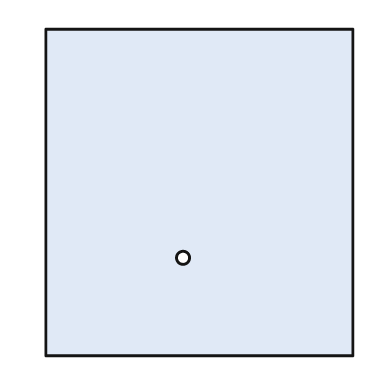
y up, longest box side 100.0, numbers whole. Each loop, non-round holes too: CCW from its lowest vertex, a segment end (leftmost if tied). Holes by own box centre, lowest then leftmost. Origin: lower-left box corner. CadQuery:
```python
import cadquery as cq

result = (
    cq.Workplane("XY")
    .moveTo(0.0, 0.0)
    .lineTo(94.0, 0.0)
    .lineTo(94.0, 100.0)
    .lineTo(0.0, 100.0)
    .close()
    .moveTo(42.0, 30.0)
    .circle(2.0)
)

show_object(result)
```